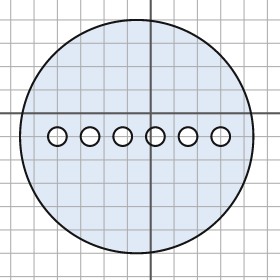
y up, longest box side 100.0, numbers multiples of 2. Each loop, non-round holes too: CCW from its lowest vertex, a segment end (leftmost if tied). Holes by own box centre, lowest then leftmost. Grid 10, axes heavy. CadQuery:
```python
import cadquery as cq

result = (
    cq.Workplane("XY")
    .moveTo(-6.0, -10.0)
    .circle(50.0)
    .moveTo(-40.0, -10.0)
    .circle(4.0)
    .moveTo(-26.0, -10.0)
    .circle(4.0)
    .moveTo(-12.0, -10.0)
    .circle(4.0)
    .moveTo(2.0, -10.0)
    .circle(4.0)
    .moveTo(16.0, -10.0)
    .circle(4.0)
    .moveTo(30.0, -10.0)
    .circle(4.0)
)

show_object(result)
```